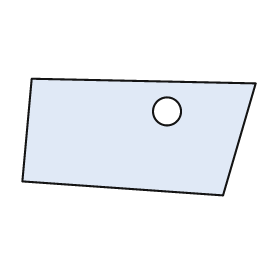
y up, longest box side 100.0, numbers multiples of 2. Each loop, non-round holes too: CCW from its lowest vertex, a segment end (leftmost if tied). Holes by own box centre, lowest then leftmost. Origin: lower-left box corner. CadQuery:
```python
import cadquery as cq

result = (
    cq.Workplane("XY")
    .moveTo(86.0, 0.0)
    .lineTo(100.0, 48.0)
    .lineTo(4.0, 50.0)
    .lineTo(0.0, 6.0)
    .close()
    .moveTo(62.0, 36.0)
    .circle(6.0)
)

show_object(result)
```